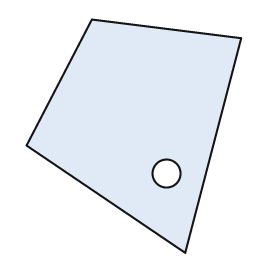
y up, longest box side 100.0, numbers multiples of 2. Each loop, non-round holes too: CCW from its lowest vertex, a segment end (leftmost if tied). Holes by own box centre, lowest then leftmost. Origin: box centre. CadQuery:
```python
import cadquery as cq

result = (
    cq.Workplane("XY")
    .moveTo(22.0, -50.0)
    .lineTo(46.0, 42.0)
    .lineTo(-18.0, 50.0)
    .lineTo(-46.0, -4.0)
    .close()
    .moveTo(14.0, -16.0)
    .circle(6.0)
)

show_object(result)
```